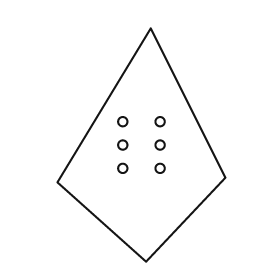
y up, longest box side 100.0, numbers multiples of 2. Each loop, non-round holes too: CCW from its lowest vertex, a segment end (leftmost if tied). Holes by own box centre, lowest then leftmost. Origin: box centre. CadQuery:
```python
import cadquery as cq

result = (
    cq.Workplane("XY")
    .moveTo(2.0, -50.0)
    .lineTo(36.0, -14.0)
    .lineTo(4.0, 50.0)
    .lineTo(-36.0, -16.0)
    .close()
    .moveTo(-8.0, -10.0)
    .circle(2.0)
    .moveTo(8.0, -10.0)
    .circle(2.0)
    .moveTo(-8.0, 0.0)
    .circle(2.0)
    .moveTo(8.0, 0.0)
    .circle(2.0)
    .moveTo(-8.0, 10.0)
    .circle(2.0)
    .moveTo(8.0, 10.0)
    .circle(2.0)
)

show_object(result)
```